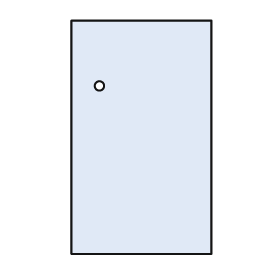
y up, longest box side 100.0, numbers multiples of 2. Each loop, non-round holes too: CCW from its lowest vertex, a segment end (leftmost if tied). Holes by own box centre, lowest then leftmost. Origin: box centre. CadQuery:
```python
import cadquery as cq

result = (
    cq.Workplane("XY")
    .moveTo(-30.0, -50.0)
    .lineTo(30.0, -50.0)
    .lineTo(30.0, 50.0)
    .lineTo(-30.0, 50.0)
    .close()
    .moveTo(-18.0, 22.0)
    .circle(2.0)
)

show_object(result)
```